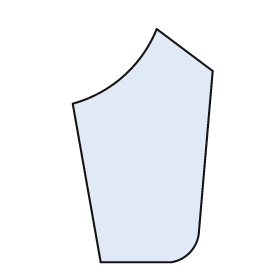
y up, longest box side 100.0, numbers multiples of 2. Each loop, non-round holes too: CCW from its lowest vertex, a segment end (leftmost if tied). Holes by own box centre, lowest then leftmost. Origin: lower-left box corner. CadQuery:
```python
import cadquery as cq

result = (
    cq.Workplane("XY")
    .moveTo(12.0, 0.0)
    .lineTo(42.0, 0.0)
    .threePointArc((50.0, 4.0), (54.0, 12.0))
    .lineTo(60.0, 82.0)
    .lineTo(36.0, 100.0)
    .threePointArc((22.0, 80.0), (0.0, 68.0))
    .close()
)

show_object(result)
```